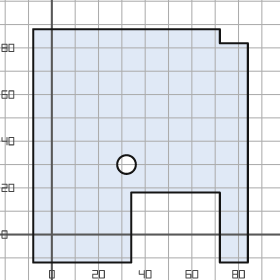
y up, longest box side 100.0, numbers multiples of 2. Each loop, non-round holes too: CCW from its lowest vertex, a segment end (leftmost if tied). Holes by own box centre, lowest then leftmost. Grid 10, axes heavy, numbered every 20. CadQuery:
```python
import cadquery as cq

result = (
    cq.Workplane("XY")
    .moveTo(-8.0, -12.0)
    .lineTo(34.0, -12.0)
    .lineTo(34.0, 18.0)
    .lineTo(72.0, 18.0)
    .lineTo(72.0, -12.0)
    .lineTo(84.0, -12.0)
    .lineTo(84.0, 82.0)
    .lineTo(72.0, 82.0)
    .lineTo(72.0, 88.0)
    .lineTo(-8.0, 88.0)
    .close()
    .moveTo(32.0, 30.0)
    .circle(4.0)
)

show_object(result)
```